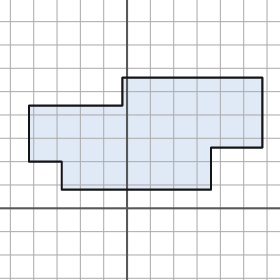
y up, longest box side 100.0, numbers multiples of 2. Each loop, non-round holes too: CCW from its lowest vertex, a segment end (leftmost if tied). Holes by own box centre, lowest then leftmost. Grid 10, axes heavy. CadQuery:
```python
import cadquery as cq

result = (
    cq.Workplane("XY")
    .moveTo(-28.0, 8.0)
    .lineTo(36.0, 8.0)
    .lineTo(36.0, 26.0)
    .lineTo(58.0, 26.0)
    .lineTo(58.0, 56.0)
    .lineTo(-2.0, 56.0)
    .lineTo(-2.0, 44.0)
    .lineTo(-42.0, 44.0)
    .lineTo(-42.0, 20.0)
    .lineTo(-28.0, 20.0)
    .close()
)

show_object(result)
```